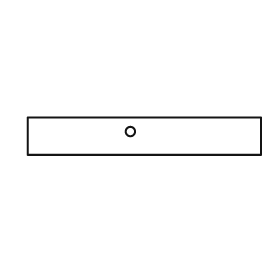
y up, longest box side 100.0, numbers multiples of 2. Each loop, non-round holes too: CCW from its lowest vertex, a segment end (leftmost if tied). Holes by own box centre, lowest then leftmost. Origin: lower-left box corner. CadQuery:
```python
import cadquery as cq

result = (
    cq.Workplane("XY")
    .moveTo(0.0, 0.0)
    .lineTo(100.0, 0.0)
    .lineTo(100.0, 16.0)
    .lineTo(0.0, 16.0)
    .close()
    .moveTo(44.0, 10.0)
    .circle(2.0)
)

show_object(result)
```